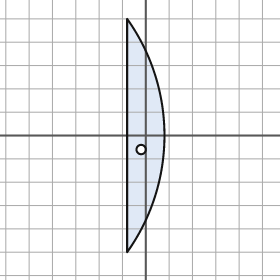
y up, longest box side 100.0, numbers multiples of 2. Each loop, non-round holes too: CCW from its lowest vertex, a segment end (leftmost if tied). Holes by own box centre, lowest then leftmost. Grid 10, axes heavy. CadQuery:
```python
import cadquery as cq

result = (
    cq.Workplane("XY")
    .moveTo(-8.0, -50.0)
    .threePointArc((8.0, 0.0), (-8.0, 50.0))
    .close()
    .moveTo(-2.0, -6.0)
    .circle(2.0)
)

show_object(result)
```